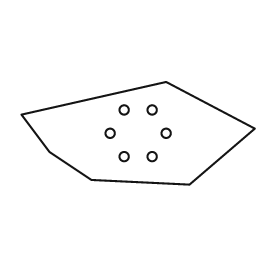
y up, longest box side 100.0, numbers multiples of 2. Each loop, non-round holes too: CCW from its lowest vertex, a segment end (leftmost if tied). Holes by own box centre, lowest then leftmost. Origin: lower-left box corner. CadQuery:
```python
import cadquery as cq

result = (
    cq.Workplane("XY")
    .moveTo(72.0, 0.0)
    .lineTo(100.0, 24.0)
    .lineTo(62.0, 44.0)
    .lineTo(0.0, 30.0)
    .lineTo(12.0, 14.0)
    .lineTo(30.0, 2.0)
    .close()
    .moveTo(44.0, 12.0)
    .circle(2.0)
    .moveTo(56.0, 12.0)
    .circle(2.0)
    .moveTo(38.0, 22.0)
    .circle(2.0)
    .moveTo(62.0, 22.0)
    .circle(2.0)
    .moveTo(44.0, 32.0)
    .circle(2.0)
    .moveTo(56.0, 32.0)
    .circle(2.0)
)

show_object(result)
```